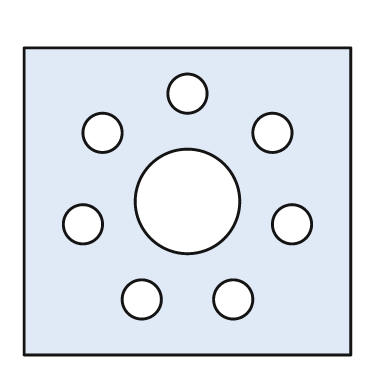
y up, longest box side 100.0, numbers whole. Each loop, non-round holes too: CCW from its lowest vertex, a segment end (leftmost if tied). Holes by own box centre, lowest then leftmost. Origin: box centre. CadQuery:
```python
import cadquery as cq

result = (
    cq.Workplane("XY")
    .moveTo(-50.0, -47.0)
    .lineTo(50.0, -47.0)
    .lineTo(50.0, 47.0)
    .lineTo(-50.0, 47.0)
    .close()
    .moveTo(-14.0, -30.0)
    .circle(6.0)
    .moveTo(14.0, -30.0)
    .circle(6.0)
    .moveTo(-32.0, -7.0)
    .circle(6.0)
    .moveTo(32.0, -7.0)
    .circle(6.0)
    .moveTo(0.0, 0.0)
    .circle(16.0)
    .moveTo(-26.0, 21.0)
    .circle(6.0)
    .moveTo(26.0, 21.0)
    .circle(6.0)
    .moveTo(0.0, 33.0)
    .circle(6.0)
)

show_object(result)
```